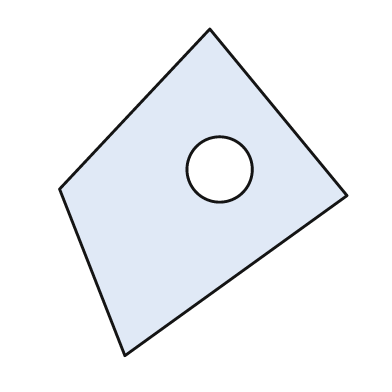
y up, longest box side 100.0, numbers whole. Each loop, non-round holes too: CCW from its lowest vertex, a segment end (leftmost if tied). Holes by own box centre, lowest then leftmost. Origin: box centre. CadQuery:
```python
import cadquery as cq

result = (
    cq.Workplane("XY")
    .moveTo(-24.0, -50.0)
    .lineTo(44.0, -1.0)
    .lineTo(2.0, 50.0)
    .lineTo(-44.0, 1.0)
    .close()
    .moveTo(5.0, 7.0)
    .circle(10.0)
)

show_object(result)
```